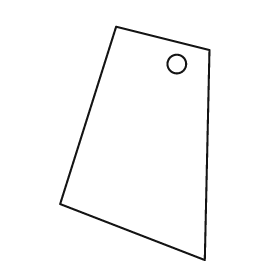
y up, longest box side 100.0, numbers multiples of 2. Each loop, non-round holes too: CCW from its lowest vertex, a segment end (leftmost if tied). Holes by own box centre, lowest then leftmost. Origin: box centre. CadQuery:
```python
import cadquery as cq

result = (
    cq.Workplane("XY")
    .moveTo(30.0, -50.0)
    .lineTo(32.0, 40.0)
    .lineTo(-8.0, 50.0)
    .lineTo(-32.0, -26.0)
    .close()
    .moveTo(18.0, 34.0)
    .circle(4.0)
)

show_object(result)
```